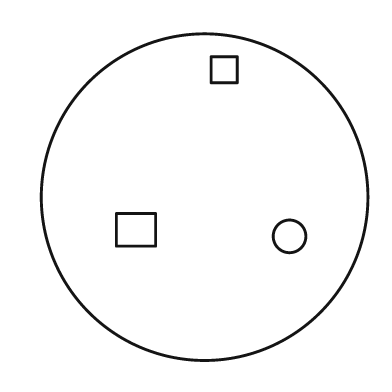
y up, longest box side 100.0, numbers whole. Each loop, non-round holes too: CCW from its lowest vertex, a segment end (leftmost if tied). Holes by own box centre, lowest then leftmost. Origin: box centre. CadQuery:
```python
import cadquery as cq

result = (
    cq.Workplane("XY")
    .moveTo(0.0, 0.0)
    .circle(50.0)
    .moveTo(26.0, -12.0)
    .circle(5.0)
    .moveTo(-27.0, -15.0)
    .lineTo(-15.0, -15.0)
    .lineTo(-15.0, -5.0)
    .lineTo(-27.0, -5.0)
    .close()
    .moveTo(2.0, 35.0)
    .lineTo(10.0, 35.0)
    .lineTo(10.0, 43.0)
    .lineTo(2.0, 43.0)
    .close()
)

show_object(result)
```